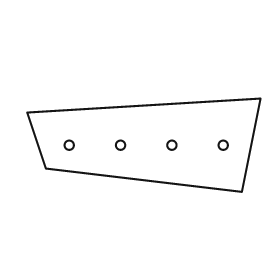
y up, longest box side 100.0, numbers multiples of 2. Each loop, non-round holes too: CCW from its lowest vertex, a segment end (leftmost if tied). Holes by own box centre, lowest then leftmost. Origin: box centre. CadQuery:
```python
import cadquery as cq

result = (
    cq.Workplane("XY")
    .moveTo(42.0, -20.0)
    .lineTo(50.0, 20.0)
    .lineTo(-50.0, 14.0)
    .lineTo(-42.0, -10.0)
    .close()
    .moveTo(-32.0, 0.0)
    .circle(2.0)
    .moveTo(-10.0, 0.0)
    .circle(2.0)
    .moveTo(12.0, 0.0)
    .circle(2.0)
    .moveTo(34.0, 0.0)
    .circle(2.0)
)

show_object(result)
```